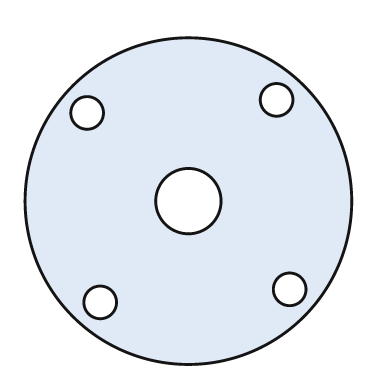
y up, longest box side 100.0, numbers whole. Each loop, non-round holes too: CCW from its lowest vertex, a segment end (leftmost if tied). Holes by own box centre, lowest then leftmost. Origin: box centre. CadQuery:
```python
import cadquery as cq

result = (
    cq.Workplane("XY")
    .moveTo(0.0, 0.0)
    .circle(50.0)
    .moveTo(-27.0, -31.0)
    .circle(5.0)
    .moveTo(31.0, -27.0)
    .circle(5.0)
    .moveTo(0.0, 0.0)
    .circle(10.0)
    .moveTo(-31.0, 27.0)
    .circle(5.0)
    .moveTo(27.0, 31.0)
    .circle(5.0)
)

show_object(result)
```